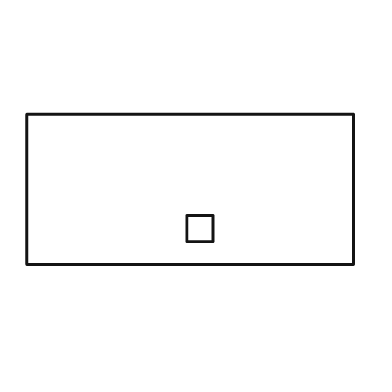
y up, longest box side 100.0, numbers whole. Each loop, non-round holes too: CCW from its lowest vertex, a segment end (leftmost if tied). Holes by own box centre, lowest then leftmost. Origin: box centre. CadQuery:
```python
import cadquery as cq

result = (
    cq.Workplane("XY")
    .moveTo(-50.0, -23.0)
    .lineTo(50.0, -23.0)
    .lineTo(50.0, 23.0)
    .lineTo(-50.0, 23.0)
    .close()
    .moveTo(-1.0, -16.0)
    .lineTo(7.0, -16.0)
    .lineTo(7.0, -8.0)
    .lineTo(-1.0, -8.0)
    .close()
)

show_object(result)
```